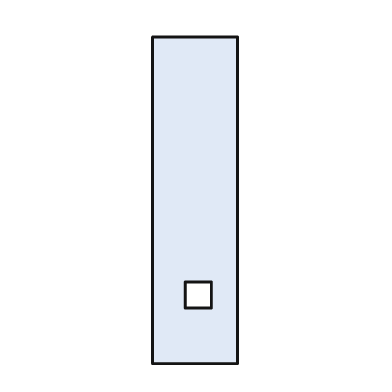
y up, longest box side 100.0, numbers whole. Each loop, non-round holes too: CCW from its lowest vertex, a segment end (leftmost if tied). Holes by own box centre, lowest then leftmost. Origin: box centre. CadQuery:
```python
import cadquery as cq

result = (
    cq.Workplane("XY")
    .moveTo(-13.0, -50.0)
    .lineTo(13.0, -50.0)
    .lineTo(13.0, 50.0)
    .lineTo(-13.0, 50.0)
    .close()
    .moveTo(-3.0, -33.0)
    .lineTo(5.0, -33.0)
    .lineTo(5.0, -25.0)
    .lineTo(-3.0, -25.0)
    .close()
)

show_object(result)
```